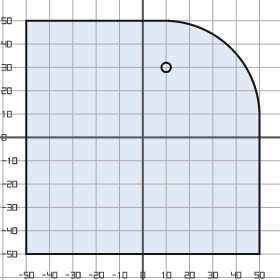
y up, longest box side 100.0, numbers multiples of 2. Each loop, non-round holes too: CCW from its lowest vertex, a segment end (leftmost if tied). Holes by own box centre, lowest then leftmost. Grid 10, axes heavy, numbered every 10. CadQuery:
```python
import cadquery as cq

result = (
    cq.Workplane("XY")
    .moveTo(-50.0, -50.0)
    .lineTo(50.0, -50.0)
    .lineTo(50.0, 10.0)
    .threePointArc((38.0, 38.0), (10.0, 50.0))
    .lineTo(-50.0, 50.0)
    .close()
    .moveTo(10.0, 30.0)
    .circle(2.0)
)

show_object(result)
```